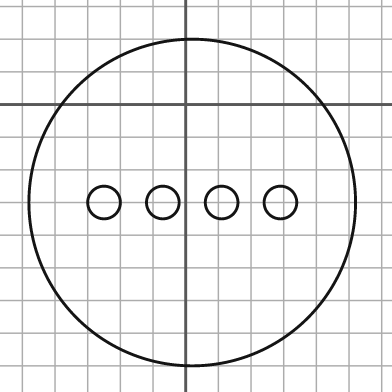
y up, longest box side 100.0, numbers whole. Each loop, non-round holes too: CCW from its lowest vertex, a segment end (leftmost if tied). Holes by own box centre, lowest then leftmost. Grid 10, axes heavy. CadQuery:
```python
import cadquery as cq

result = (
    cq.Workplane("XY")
    .moveTo(2.0, -30.0)
    .circle(50.0)
    .moveTo(-25.0, -30.0)
    .circle(5.0)
    .moveTo(-7.0, -30.0)
    .circle(5.0)
    .moveTo(11.0, -30.0)
    .circle(5.0)
    .moveTo(29.0, -30.0)
    .circle(5.0)
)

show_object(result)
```